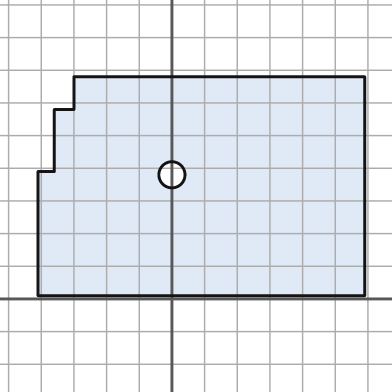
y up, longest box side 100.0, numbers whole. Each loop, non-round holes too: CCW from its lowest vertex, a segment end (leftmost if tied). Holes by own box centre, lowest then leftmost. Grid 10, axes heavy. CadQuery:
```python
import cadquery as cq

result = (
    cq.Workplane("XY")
    .moveTo(-41.0, 1.0)
    .lineTo(59.0, 1.0)
    .lineTo(59.0, 68.0)
    .lineTo(-30.0, 68.0)
    .lineTo(-30.0, 58.0)
    .lineTo(-36.0, 58.0)
    .lineTo(-36.0, 39.0)
    .lineTo(-41.0, 39.0)
    .close()
    .moveTo(0.0, 38.0)
    .circle(4.0)
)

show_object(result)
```